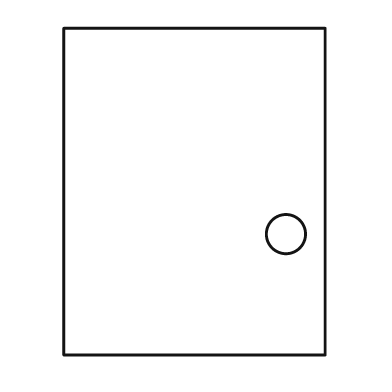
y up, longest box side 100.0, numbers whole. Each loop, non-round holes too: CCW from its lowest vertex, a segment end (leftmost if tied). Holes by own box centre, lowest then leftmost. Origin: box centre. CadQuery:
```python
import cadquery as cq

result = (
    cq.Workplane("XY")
    .moveTo(-40.0, -50.0)
    .lineTo(40.0, -50.0)
    .lineTo(40.0, 50.0)
    .lineTo(-40.0, 50.0)
    .close()
    .moveTo(28.0, -13.0)
    .circle(6.0)
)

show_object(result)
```